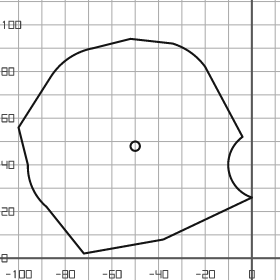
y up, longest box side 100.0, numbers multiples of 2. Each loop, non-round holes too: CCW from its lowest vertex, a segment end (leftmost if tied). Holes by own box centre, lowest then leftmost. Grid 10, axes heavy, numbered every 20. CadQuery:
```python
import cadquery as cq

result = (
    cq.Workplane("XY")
    .moveTo(-72.0, 2.0)
    .lineTo(-38.0, 8.0)
    .lineTo(0.0, 26.0)
    .threePointArc((-10.0, 38.0), (-4.0, 52.0))
    .lineTo(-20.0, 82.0)
    .threePointArc((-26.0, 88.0), (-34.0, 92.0))
    .lineTo(-52.0, 94.0)
    .lineTo(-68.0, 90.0)
    .threePointArc((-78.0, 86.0), (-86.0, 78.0))
    .lineTo(-100.0, 56.0)
    .lineTo(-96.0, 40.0)
    .threePointArc((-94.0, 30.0), (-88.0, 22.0))
    .close()
    .moveTo(-50.0, 48.0)
    .circle(2.0)
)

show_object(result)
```